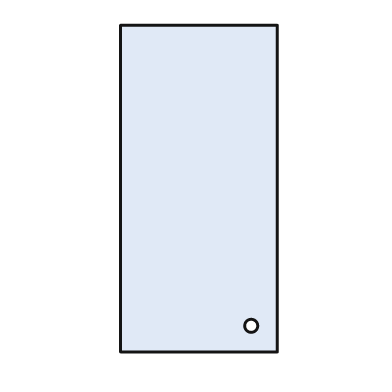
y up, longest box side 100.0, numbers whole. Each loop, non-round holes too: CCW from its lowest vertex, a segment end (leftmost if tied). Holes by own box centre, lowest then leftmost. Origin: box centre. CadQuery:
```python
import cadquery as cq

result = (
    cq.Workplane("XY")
    .moveTo(-24.0, -50.0)
    .lineTo(24.0, -50.0)
    .lineTo(24.0, 50.0)
    .lineTo(-24.0, 50.0)
    .close()
    .moveTo(16.0, -42.0)
    .circle(2.0)
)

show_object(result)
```